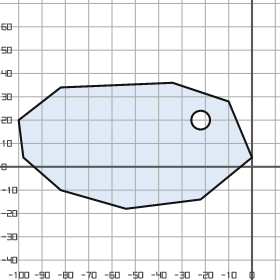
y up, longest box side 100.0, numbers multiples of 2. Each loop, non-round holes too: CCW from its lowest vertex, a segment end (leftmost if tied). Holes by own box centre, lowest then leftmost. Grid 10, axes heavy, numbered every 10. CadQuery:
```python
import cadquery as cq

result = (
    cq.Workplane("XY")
    .moveTo(-54.0, -18.0)
    .lineTo(-22.0, -14.0)
    .lineTo(0.0, 4.0)
    .lineTo(-10.0, 28.0)
    .lineTo(-34.0, 36.0)
    .lineTo(-82.0, 34.0)
    .lineTo(-100.0, 20.0)
    .lineTo(-98.0, 4.0)
    .lineTo(-82.0, -10.0)
    .close()
    .moveTo(-22.0, 20.0)
    .circle(4.0)
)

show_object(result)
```